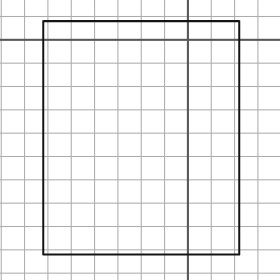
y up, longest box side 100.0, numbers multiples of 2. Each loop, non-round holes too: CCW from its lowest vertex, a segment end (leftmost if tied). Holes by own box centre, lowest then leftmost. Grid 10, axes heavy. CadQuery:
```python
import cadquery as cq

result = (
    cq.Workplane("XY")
    .moveTo(-62.0, -92.0)
    .lineTo(22.0, -92.0)
    .lineTo(22.0, 8.0)
    .lineTo(-62.0, 8.0)
    .close()
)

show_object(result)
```